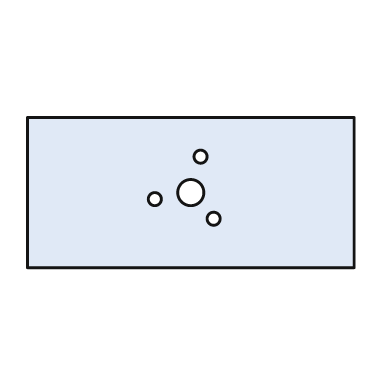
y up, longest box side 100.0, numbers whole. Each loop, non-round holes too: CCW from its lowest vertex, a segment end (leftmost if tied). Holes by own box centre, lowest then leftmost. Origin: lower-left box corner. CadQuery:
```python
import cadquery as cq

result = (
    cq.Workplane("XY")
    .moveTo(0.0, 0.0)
    .lineTo(100.0, 0.0)
    .lineTo(100.0, 46.0)
    .lineTo(0.0, 46.0)
    .close()
    .moveTo(57.0, 15.0)
    .circle(2.0)
    .moveTo(39.0, 21.0)
    .circle(2.0)
    .moveTo(50.0, 23.0)
    .circle(4.0)
    .moveTo(53.0, 34.0)
    .circle(2.0)
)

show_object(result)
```